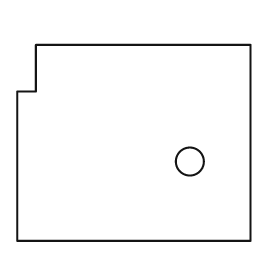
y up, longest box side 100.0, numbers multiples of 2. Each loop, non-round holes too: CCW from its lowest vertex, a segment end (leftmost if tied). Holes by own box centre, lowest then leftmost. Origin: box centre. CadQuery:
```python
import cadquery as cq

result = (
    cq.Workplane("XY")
    .moveTo(-50.0, -42.0)
    .lineTo(50.0, -42.0)
    .lineTo(50.0, 42.0)
    .lineTo(-42.0, 42.0)
    .lineTo(-42.0, 22.0)
    .lineTo(-50.0, 22.0)
    .close()
    .moveTo(24.0, -8.0)
    .circle(6.0)
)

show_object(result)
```